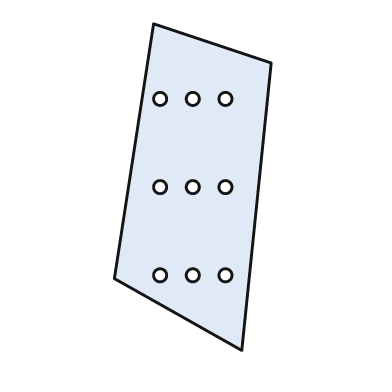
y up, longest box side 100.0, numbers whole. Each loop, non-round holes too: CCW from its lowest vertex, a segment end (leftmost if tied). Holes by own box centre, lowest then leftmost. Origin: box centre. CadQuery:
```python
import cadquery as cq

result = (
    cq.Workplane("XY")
    .moveTo(15.0, -50.0)
    .lineTo(24.0, 38.0)
    .lineTo(-12.0, 50.0)
    .lineTo(-24.0, -28.0)
    .close()
    .moveTo(-10.0, -27.0)
    .circle(2.0)
    .moveTo(0.0, -27.0)
    .circle(2.0)
    .moveTo(10.0, -27.0)
    .circle(2.0)
    .moveTo(-10.0, 0.0)
    .circle(2.0)
    .moveTo(0.0, 0.0)
    .circle(2.0)
    .moveTo(10.0, 0.0)
    .circle(2.0)
    .moveTo(-10.0, 27.0)
    .circle(2.0)
    .moveTo(0.0, 27.0)
    .circle(2.0)
    .moveTo(10.0, 27.0)
    .circle(2.0)
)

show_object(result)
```